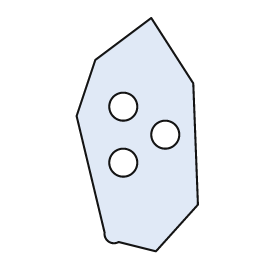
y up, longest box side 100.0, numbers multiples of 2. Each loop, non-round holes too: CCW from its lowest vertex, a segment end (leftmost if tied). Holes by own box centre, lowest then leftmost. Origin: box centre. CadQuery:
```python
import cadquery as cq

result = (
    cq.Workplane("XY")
    .moveTo(8.0, -50.0)
    .lineTo(26.0, -30.0)
    .lineTo(24.0, 22.0)
    .lineTo(6.0, 50.0)
    .lineTo(-18.0, 32.0)
    .lineTo(-26.0, 8.0)
    .lineTo(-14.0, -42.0)
    .threePointArc((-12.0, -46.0), (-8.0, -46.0))
    .close()
    .moveTo(-6.0, -12.0)
    .circle(6.0)
    .moveTo(12.0, 0.0)
    .circle(6.0)
    .moveTo(-6.0, 12.0)
    .circle(6.0)
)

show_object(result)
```